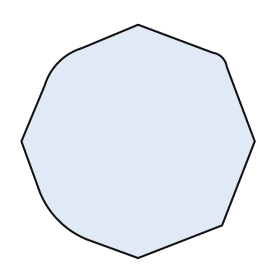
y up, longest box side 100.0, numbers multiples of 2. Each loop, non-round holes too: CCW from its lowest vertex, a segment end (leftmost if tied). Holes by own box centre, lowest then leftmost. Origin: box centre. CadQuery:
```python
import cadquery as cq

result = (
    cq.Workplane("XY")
    .moveTo(0.0, -50.0)
    .lineTo(36.0, -36.0)
    .lineTo(50.0, 0.0)
    .lineTo(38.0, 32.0)
    .threePointArc((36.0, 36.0), (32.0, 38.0))
    .lineTo(0.0, 50.0)
    .lineTo(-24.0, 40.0)
    .threePointArc((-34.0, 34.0), (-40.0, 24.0))
    .lineTo(-50.0, 0.0)
    .lineTo(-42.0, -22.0)
    .threePointArc((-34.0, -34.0), (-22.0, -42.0))
    .close()
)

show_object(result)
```